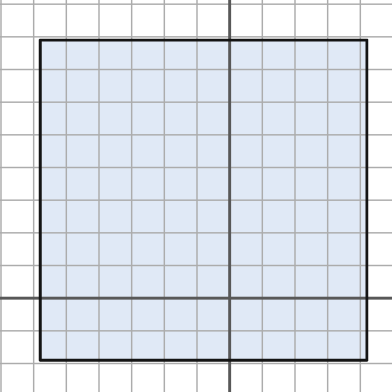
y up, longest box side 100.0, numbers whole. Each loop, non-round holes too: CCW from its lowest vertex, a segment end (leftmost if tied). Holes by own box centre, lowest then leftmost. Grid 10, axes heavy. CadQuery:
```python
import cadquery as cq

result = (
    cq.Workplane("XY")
    .moveTo(-58.0, -19.0)
    .lineTo(42.0, -19.0)
    .lineTo(42.0, 79.0)
    .lineTo(-58.0, 79.0)
    .close()
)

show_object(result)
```